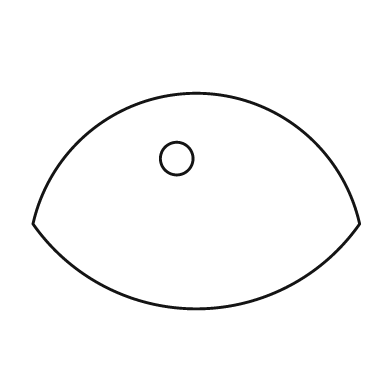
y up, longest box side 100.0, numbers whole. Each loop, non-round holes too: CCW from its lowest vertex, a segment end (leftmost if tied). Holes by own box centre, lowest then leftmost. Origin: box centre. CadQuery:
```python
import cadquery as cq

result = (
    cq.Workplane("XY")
    .moveTo(-50.0, -7.0)
    .threePointArc((0.0, -33.0), (50.0, -7.0))
    .threePointArc((0.0, 33.0), (-50.0, -7.0))
    .close()
    .moveTo(-6.0, 13.0)
    .circle(5.0)
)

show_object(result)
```